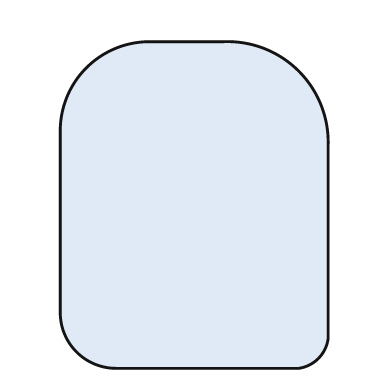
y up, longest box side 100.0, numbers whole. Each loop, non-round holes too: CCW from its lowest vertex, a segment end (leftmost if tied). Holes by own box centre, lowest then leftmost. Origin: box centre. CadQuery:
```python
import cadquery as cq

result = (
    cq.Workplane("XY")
    .moveTo(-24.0, -50.0)
    .lineTo(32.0, -50.0)
    .threePointArc((38.0, -47.0), (41.0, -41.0))
    .lineTo(41.0, 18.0)
    .threePointArc((32.0, 41.0), (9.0, 50.0))
    .lineTo(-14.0, 50.0)
    .threePointArc((-33.0, 42.0), (-41.0, 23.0))
    .lineTo(-41.0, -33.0)
    .threePointArc((-36.0, -45.0), (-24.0, -50.0))
    .close()
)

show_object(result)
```